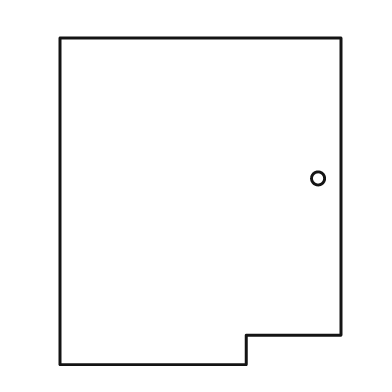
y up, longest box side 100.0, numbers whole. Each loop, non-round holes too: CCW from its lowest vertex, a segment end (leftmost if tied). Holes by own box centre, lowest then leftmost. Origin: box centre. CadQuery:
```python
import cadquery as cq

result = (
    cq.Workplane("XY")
    .moveTo(-43.0, -50.0)
    .lineTo(14.0, -50.0)
    .lineTo(14.0, -41.0)
    .lineTo(43.0, -41.0)
    .lineTo(43.0, 50.0)
    .lineTo(-43.0, 50.0)
    .close()
    .moveTo(36.0, 7.0)
    .circle(2.0)
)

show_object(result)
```